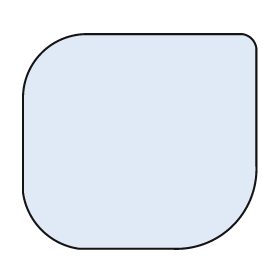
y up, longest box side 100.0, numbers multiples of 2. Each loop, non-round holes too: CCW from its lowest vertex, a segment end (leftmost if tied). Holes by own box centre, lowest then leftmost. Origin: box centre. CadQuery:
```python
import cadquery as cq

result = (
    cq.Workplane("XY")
    .moveTo(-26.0, -46.0)
    .lineTo(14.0, -46.0)
    .threePointArc((40.0, -36.0), (50.0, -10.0))
    .lineTo(50.0, 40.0)
    .threePointArc((48.0, 44.0), (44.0, 46.0))
    .lineTo(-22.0, 46.0)
    .threePointArc((-42.0, 38.0), (-50.0, 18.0))
    .lineTo(-50.0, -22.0)
    .threePointArc((-42.0, -38.0), (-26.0, -46.0))
    .close()
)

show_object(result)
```